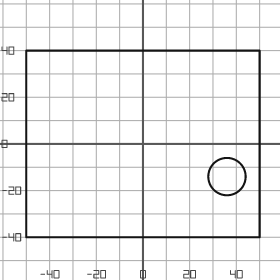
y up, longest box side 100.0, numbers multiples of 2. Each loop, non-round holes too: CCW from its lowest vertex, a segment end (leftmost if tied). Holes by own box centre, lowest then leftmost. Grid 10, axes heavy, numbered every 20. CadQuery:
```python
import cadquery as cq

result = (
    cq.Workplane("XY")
    .moveTo(-50.0, -40.0)
    .lineTo(50.0, -40.0)
    .lineTo(50.0, 40.0)
    .lineTo(-50.0, 40.0)
    .close()
    .moveTo(36.0, -14.0)
    .circle(8.0)
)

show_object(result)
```